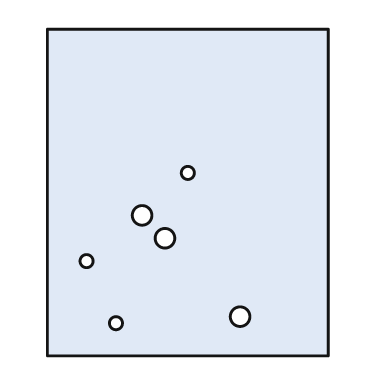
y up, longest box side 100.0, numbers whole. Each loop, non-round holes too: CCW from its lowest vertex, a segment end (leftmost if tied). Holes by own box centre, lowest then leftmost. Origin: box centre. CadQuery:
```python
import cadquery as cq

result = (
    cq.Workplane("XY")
    .moveTo(-43.0, -50.0)
    .lineTo(43.0, -50.0)
    .lineTo(43.0, 50.0)
    .lineTo(-43.0, 50.0)
    .close()
    .moveTo(-22.0, -40.0)
    .circle(2.0)
    .moveTo(16.0, -38.0)
    .circle(3.0)
    .moveTo(-31.0, -21.0)
    .circle(2.0)
    .moveTo(-7.0, -14.0)
    .circle(3.0)
    .moveTo(-14.0, -7.0)
    .circle(3.0)
    .moveTo(0.0, 6.0)
    .circle(2.0)
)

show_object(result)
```